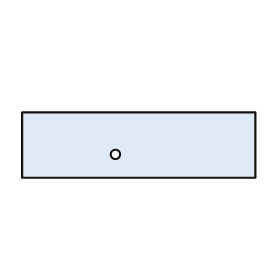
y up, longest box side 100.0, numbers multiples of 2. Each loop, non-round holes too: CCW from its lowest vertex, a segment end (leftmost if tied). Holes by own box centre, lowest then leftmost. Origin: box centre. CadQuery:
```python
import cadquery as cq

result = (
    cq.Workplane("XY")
    .moveTo(-50.0, -14.0)
    .lineTo(50.0, -14.0)
    .lineTo(50.0, 14.0)
    .lineTo(-50.0, 14.0)
    .close()
    .moveTo(-10.0, -4.0)
    .circle(2.0)
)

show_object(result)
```